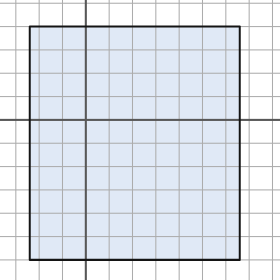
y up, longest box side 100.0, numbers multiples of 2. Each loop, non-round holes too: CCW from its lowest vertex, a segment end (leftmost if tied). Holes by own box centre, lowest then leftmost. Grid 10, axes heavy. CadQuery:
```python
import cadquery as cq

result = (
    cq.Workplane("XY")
    .moveTo(-24.0, -60.0)
    .lineTo(66.0, -60.0)
    .lineTo(66.0, 40.0)
    .lineTo(-24.0, 40.0)
    .close()
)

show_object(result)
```